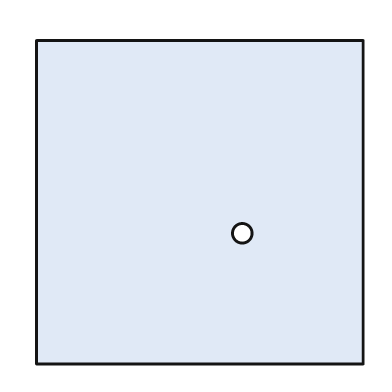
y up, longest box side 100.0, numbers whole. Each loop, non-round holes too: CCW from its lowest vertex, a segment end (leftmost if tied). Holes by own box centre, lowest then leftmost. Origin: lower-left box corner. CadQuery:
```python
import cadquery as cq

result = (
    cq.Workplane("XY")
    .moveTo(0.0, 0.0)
    .lineTo(100.0, 0.0)
    .lineTo(100.0, 99.0)
    .lineTo(0.0, 99.0)
    .close()
    .moveTo(63.0, 40.0)
    .circle(3.0)
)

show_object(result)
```